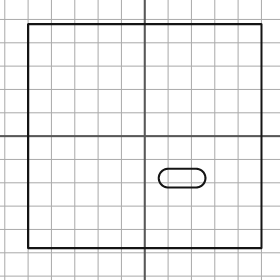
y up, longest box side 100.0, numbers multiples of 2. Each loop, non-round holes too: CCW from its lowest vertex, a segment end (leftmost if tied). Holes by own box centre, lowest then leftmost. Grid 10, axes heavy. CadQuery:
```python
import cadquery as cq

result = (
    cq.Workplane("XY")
    .moveTo(-50.0, -48.0)
    .lineTo(50.0, -48.0)
    .lineTo(50.0, 48.0)
    .lineTo(-50.0, 48.0)
    .close()
    .moveTo(10.0, -22.0)
    .lineTo(22.0, -22.0)
    .threePointArc((26.0, -18.0), (22.0, -14.0))
    .lineTo(10.0, -14.0)
    .threePointArc((6.0, -18.0), (10.0, -22.0))
    .close()
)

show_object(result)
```